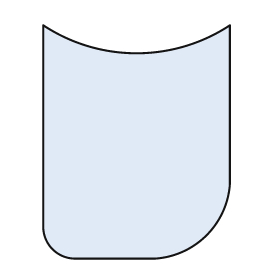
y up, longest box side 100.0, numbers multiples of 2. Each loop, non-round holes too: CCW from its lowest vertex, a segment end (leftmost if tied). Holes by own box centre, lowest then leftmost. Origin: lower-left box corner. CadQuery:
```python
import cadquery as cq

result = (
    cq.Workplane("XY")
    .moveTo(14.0, 0.0)
    .lineTo(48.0, 0.0)
    .threePointArc((70.0, 10.0), (80.0, 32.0))
    .lineTo(80.0, 100.0)
    .threePointArc((40.0, 88.0), (0.0, 100.0))
    .lineTo(0.0, 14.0)
    .threePointArc((4.0, 4.0), (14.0, 0.0))
    .close()
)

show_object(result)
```